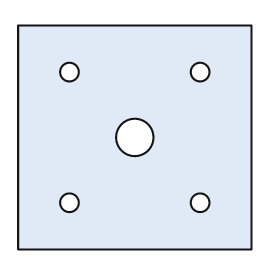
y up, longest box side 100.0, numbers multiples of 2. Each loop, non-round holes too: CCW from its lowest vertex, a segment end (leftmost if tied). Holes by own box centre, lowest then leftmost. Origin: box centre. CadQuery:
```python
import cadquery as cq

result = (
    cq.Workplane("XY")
    .moveTo(-50.0, -48.0)
    .lineTo(50.0, -48.0)
    .lineTo(50.0, 48.0)
    .lineTo(-50.0, 48.0)
    .close()
    .moveTo(-28.0, -28.0)
    .circle(4.0)
    .moveTo(28.0, -28.0)
    .circle(4.0)
    .moveTo(0.0, 0.0)
    .circle(8.0)
    .moveTo(-28.0, 28.0)
    .circle(4.0)
    .moveTo(28.0, 28.0)
    .circle(4.0)
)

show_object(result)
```